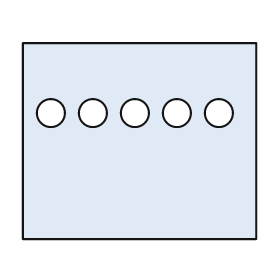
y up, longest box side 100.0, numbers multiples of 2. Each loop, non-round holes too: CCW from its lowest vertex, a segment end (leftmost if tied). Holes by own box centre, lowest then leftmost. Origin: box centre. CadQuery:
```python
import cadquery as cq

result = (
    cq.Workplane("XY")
    .moveTo(-50.0, -42.0)
    .lineTo(50.0, -42.0)
    .lineTo(50.0, 42.0)
    .lineTo(-50.0, 42.0)
    .close()
    .moveTo(-38.0, 12.0)
    .circle(6.0)
    .moveTo(-20.0, 12.0)
    .circle(6.0)
    .moveTo(-2.0, 12.0)
    .circle(6.0)
    .moveTo(16.0, 12.0)
    .circle(6.0)
    .moveTo(34.0, 12.0)
    .circle(6.0)
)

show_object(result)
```